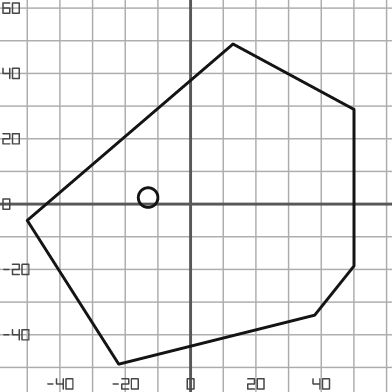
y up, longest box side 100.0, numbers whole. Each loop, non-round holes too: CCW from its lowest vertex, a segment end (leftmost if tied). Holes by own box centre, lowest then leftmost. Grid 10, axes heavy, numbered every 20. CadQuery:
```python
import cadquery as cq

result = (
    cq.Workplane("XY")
    .moveTo(-22.0, -49.0)
    .lineTo(38.0, -34.0)
    .lineTo(50.0, -19.0)
    .lineTo(50.0, 29.0)
    .lineTo(13.0, 49.0)
    .lineTo(-50.0, -5.0)
    .close()
    .moveTo(-13.0, 2.0)
    .circle(3.0)
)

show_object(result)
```